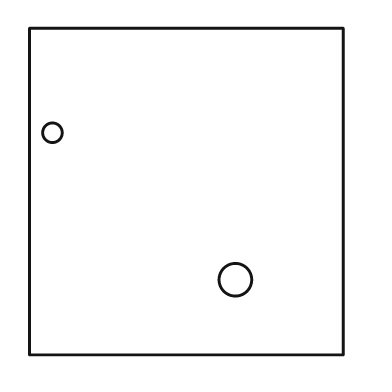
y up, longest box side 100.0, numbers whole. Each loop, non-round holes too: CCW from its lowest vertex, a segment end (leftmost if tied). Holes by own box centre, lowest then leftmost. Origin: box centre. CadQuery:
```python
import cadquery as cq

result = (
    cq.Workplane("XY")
    .moveTo(-48.0, -50.0)
    .lineTo(48.0, -50.0)
    .lineTo(48.0, 50.0)
    .lineTo(-48.0, 50.0)
    .close()
    .moveTo(15.0, -27.0)
    .circle(5.0)
    .moveTo(-41.0, 18.0)
    .circle(3.0)
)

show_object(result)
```